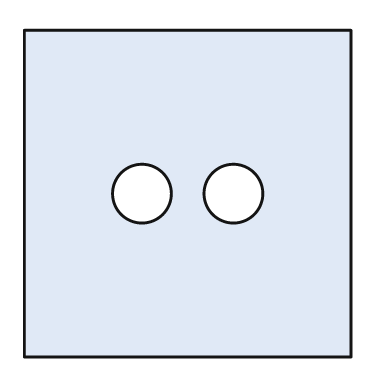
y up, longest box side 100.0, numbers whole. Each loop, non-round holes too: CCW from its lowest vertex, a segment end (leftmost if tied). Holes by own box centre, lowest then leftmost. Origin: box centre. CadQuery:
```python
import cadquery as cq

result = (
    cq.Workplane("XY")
    .moveTo(-50.0, -50.0)
    .lineTo(50.0, -50.0)
    .lineTo(50.0, 50.0)
    .lineTo(-50.0, 50.0)
    .close()
    .moveTo(-14.0, 0.0)
    .circle(9.0)
    .moveTo(14.0, 0.0)
    .circle(9.0)
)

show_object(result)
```